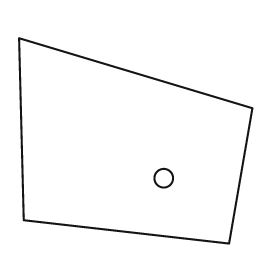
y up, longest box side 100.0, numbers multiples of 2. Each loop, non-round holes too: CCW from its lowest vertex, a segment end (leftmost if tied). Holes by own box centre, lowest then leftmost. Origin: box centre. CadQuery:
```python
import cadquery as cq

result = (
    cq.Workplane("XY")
    .moveTo(40.0, -44.0)
    .lineTo(50.0, 14.0)
    .lineTo(-50.0, 44.0)
    .lineTo(-48.0, -34.0)
    .close()
    .moveTo(12.0, -16.0)
    .circle(4.0)
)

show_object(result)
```